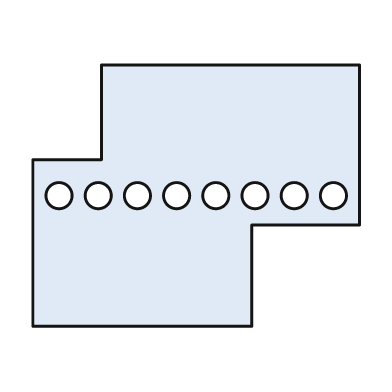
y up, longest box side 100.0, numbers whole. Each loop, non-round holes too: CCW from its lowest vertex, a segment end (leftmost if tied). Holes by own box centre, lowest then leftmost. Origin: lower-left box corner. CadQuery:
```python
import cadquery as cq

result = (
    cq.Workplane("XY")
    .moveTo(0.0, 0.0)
    .lineTo(67.0, 0.0)
    .lineTo(67.0, 31.0)
    .lineTo(100.0, 31.0)
    .lineTo(100.0, 80.0)
    .lineTo(21.0, 80.0)
    .lineTo(21.0, 51.0)
    .lineTo(0.0, 51.0)
    .close()
    .moveTo(8.0, 40.0)
    .circle(4.0)
    .moveTo(20.0, 40.0)
    .circle(4.0)
    .moveTo(32.0, 40.0)
    .circle(4.0)
    .moveTo(44.0, 40.0)
    .circle(4.0)
    .moveTo(56.0, 40.0)
    .circle(4.0)
    .moveTo(68.0, 40.0)
    .circle(4.0)
    .moveTo(80.0, 40.0)
    .circle(4.0)
    .moveTo(92.0, 40.0)
    .circle(4.0)
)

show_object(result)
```